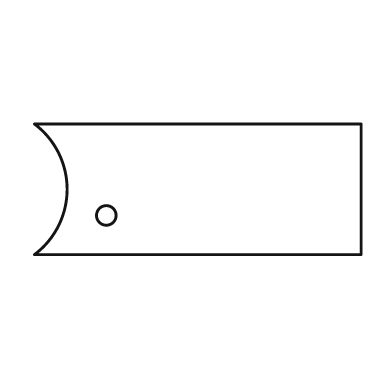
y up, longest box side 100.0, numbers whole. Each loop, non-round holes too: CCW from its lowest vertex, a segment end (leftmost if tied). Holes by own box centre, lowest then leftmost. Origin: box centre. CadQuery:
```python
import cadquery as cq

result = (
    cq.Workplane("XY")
    .moveTo(-50.0, -20.0)
    .lineTo(50.0, -20.0)
    .lineTo(50.0, 20.0)
    .lineTo(-50.0, 20.0)
    .threePointArc((-40.0, 0.0), (-50.0, -20.0))
    .close()
    .moveTo(-28.0, -8.0)
    .circle(3.0)
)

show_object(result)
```